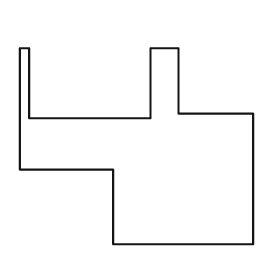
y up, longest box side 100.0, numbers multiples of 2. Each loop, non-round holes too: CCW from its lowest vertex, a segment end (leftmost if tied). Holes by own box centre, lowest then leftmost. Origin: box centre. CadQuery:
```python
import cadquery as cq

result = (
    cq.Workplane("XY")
    .moveTo(-10.0, -42.0)
    .lineTo(50.0, -42.0)
    .lineTo(50.0, 14.0)
    .lineTo(18.0, 14.0)
    .lineTo(18.0, 42.0)
    .lineTo(6.0, 42.0)
    .lineTo(6.0, 12.0)
    .lineTo(-46.0, 12.0)
    .lineTo(-46.0, 42.0)
    .lineTo(-50.0, 42.0)
    .lineTo(-50.0, -10.0)
    .lineTo(-10.0, -10.0)
    .close()
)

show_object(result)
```